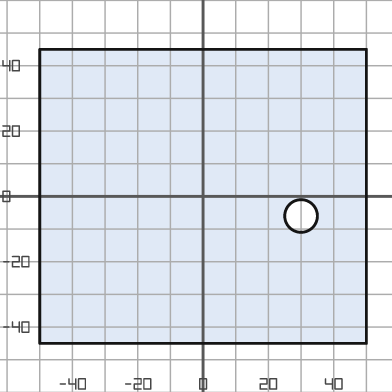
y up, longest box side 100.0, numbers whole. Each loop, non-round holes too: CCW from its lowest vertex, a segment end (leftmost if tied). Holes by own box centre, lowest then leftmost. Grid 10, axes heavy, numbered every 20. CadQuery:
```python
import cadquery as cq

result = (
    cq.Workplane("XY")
    .moveTo(-50.0, -45.0)
    .lineTo(50.0, -45.0)
    .lineTo(50.0, 45.0)
    .lineTo(-50.0, 45.0)
    .close()
    .moveTo(30.0, -6.0)
    .circle(5.0)
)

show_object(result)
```